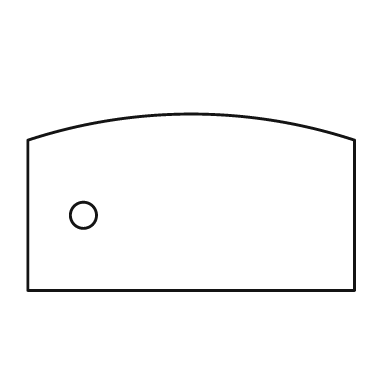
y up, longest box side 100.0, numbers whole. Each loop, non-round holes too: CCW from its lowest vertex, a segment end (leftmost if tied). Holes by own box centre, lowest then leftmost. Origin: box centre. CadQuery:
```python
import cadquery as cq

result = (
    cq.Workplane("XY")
    .moveTo(-50.0, -27.0)
    .lineTo(50.0, -27.0)
    .lineTo(50.0, 19.0)
    .threePointArc((0.0, 27.0), (-50.0, 19.0))
    .close()
    .moveTo(-33.0, -4.0)
    .circle(4.0)
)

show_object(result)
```